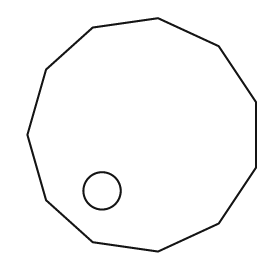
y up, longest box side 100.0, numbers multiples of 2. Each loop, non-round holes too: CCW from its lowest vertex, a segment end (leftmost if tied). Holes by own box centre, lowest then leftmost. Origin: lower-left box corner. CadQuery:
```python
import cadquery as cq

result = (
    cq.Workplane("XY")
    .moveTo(56.0, 0.0)
    .lineTo(82.0, 12.0)
    .lineTo(98.0, 36.0)
    .lineTo(98.0, 64.0)
    .lineTo(82.0, 88.0)
    .lineTo(56.0, 100.0)
    .lineTo(28.0, 96.0)
    .lineTo(8.0, 78.0)
    .lineTo(0.0, 50.0)
    .lineTo(8.0, 22.0)
    .lineTo(28.0, 4.0)
    .close()
    .moveTo(32.0, 26.0)
    .circle(8.0)
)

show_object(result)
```